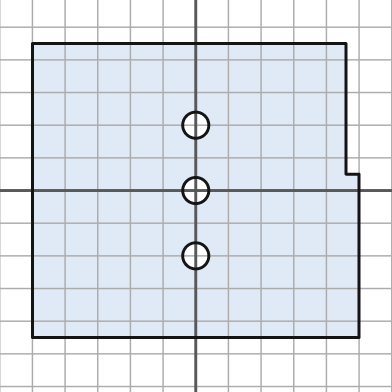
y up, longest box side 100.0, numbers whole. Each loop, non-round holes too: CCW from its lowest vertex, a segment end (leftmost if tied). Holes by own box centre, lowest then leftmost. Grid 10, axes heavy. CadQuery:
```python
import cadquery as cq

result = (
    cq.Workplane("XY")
    .moveTo(-50.0, -45.0)
    .lineTo(50.0, -45.0)
    .lineTo(50.0, 5.0)
    .lineTo(46.0, 5.0)
    .lineTo(46.0, 45.0)
    .lineTo(-50.0, 45.0)
    .close()
    .moveTo(0.0, -20.0)
    .circle(4.0)
    .moveTo(0.0, 0.0)
    .circle(4.0)
    .moveTo(0.0, 20.0)
    .circle(4.0)
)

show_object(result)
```